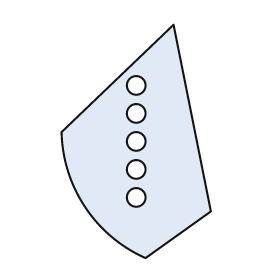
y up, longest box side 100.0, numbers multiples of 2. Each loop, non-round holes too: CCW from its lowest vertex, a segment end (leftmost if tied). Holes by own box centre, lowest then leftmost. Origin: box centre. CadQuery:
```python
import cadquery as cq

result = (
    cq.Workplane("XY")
    .moveTo(4.0, -50.0)
    .lineTo(32.0, -30.0)
    .lineTo(16.0, 50.0)
    .lineTo(-32.0, 4.0)
    .threePointArc((-22.0, -28.0), (4.0, -50.0))
    .close()
    .moveTo(0.0, -24.0)
    .circle(4.0)
    .moveTo(0.0, -12.0)
    .circle(4.0)
    .moveTo(0.0, 0.0)
    .circle(4.0)
    .moveTo(0.0, 12.0)
    .circle(4.0)
    .moveTo(0.0, 24.0)
    .circle(4.0)
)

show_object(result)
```